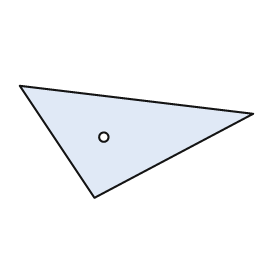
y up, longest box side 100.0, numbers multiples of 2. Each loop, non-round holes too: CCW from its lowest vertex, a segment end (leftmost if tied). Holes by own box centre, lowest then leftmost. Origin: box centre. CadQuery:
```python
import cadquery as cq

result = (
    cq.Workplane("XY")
    .moveTo(-18.0, -24.0)
    .lineTo(50.0, 12.0)
    .lineTo(-50.0, 24.0)
    .close()
    .moveTo(-14.0, 2.0)
    .circle(2.0)
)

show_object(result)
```